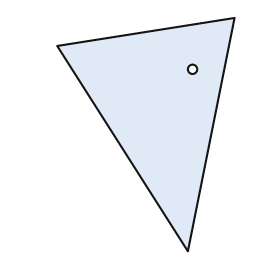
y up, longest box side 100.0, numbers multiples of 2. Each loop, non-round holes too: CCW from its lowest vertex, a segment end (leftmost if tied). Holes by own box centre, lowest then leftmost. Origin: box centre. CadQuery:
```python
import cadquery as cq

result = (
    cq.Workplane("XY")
    .moveTo(18.0, -50.0)
    .lineTo(38.0, 50.0)
    .lineTo(-38.0, 38.0)
    .close()
    .moveTo(20.0, 28.0)
    .circle(2.0)
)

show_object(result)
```